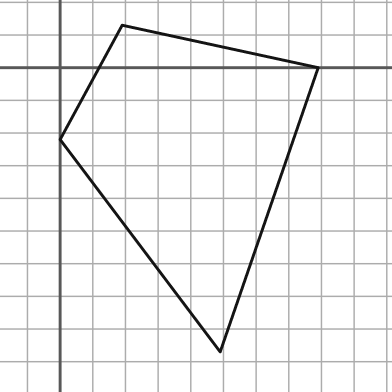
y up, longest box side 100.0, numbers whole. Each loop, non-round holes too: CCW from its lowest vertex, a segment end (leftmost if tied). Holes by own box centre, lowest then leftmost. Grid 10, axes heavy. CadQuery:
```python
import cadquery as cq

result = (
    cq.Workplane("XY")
    .moveTo(49.0, -87.0)
    .lineTo(79.0, 0.0)
    .lineTo(19.0, 13.0)
    .lineTo(0.0, -22.0)
    .close()
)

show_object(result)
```